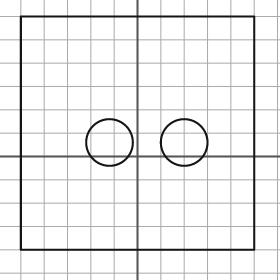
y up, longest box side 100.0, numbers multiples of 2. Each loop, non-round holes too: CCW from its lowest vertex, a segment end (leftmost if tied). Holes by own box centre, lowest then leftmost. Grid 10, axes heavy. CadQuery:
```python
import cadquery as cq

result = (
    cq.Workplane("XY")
    .moveTo(-50.0, -40.0)
    .lineTo(50.0, -40.0)
    .lineTo(50.0, 60.0)
    .lineTo(-50.0, 60.0)
    .close()
    .moveTo(-12.0, 6.0)
    .circle(10.0)
    .moveTo(20.0, 6.0)
    .circle(10.0)
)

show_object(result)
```